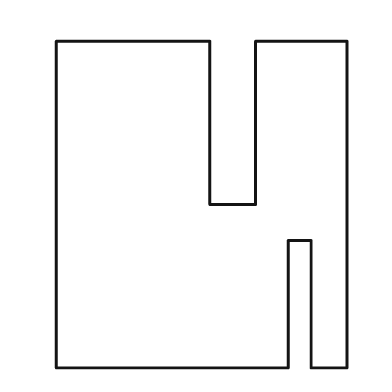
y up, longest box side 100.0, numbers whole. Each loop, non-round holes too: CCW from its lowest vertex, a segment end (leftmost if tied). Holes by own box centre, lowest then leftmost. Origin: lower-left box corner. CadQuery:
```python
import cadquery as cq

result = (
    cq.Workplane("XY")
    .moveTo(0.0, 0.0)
    .lineTo(71.0, 0.0)
    .lineTo(71.0, 39.0)
    .lineTo(78.0, 39.0)
    .lineTo(78.0, 0.0)
    .lineTo(89.0, 0.0)
    .lineTo(89.0, 100.0)
    .lineTo(61.0, 100.0)
    .lineTo(61.0, 50.0)
    .lineTo(47.0, 50.0)
    .lineTo(47.0, 100.0)
    .lineTo(0.0, 100.0)
    .close()
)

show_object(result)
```